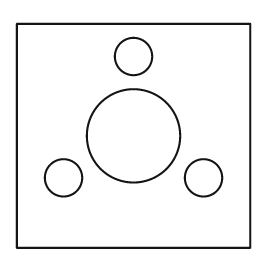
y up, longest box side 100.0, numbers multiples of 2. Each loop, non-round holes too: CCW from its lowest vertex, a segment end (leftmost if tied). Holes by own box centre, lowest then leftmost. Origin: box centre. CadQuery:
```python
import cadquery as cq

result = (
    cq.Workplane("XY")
    .moveTo(-50.0, -48.0)
    .lineTo(50.0, -48.0)
    .lineTo(50.0, 48.0)
    .lineTo(-50.0, 48.0)
    .close()
    .moveTo(-30.0, -18.0)
    .circle(8.0)
    .moveTo(30.0, -18.0)
    .circle(8.0)
    .moveTo(0.0, 0.0)
    .circle(20.0)
    .moveTo(0.0, 34.0)
    .circle(8.0)
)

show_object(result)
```